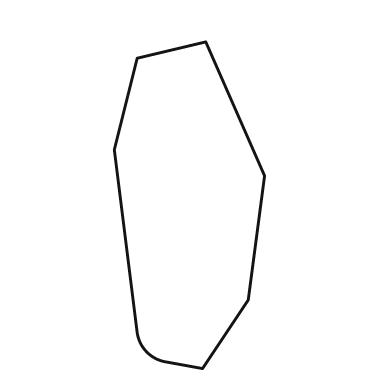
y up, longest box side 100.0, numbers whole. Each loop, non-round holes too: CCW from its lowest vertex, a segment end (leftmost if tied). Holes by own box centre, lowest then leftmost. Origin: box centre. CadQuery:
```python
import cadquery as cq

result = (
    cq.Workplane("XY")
    .moveTo(4.0, -50.0)
    .lineTo(18.0, -29.0)
    .lineTo(23.0, 9.0)
    .lineTo(5.0, 50.0)
    .lineTo(-16.0, 45.0)
    .lineTo(-23.0, 17.0)
    .lineTo(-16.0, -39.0)
    .threePointArc((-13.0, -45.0), (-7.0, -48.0))
    .close()
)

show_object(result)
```